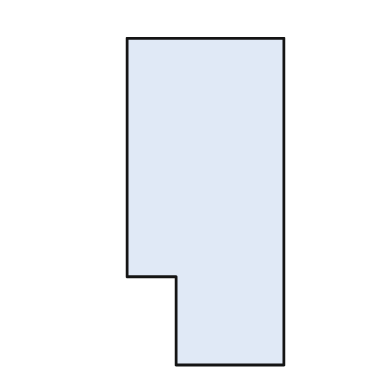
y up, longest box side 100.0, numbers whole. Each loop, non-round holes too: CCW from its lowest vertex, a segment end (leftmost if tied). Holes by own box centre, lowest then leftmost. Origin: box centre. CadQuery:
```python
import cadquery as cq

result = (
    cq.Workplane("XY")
    .moveTo(-9.0, -50.0)
    .lineTo(24.0, -50.0)
    .lineTo(24.0, 50.0)
    .lineTo(-24.0, 50.0)
    .lineTo(-24.0, -23.0)
    .lineTo(-9.0, -23.0)
    .close()
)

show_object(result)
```